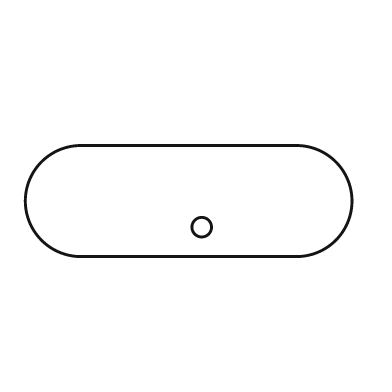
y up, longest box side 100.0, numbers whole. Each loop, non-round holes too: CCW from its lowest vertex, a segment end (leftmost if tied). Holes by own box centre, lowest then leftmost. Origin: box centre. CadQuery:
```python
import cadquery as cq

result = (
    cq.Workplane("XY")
    .moveTo(-33.0, -17.0)
    .lineTo(33.0, -17.0)
    .threePointArc((50.0, 0.0), (33.0, 17.0))
    .lineTo(-33.0, 17.0)
    .threePointArc((-50.0, 0.0), (-33.0, -17.0))
    .close()
    .moveTo(4.0, -8.0)
    .circle(3.0)
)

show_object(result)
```